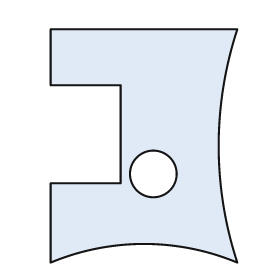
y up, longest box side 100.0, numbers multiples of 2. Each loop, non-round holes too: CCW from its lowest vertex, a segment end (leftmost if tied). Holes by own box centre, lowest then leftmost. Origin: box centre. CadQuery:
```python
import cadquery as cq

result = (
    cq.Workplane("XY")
    .moveTo(-40.0, -50.0)
    .threePointArc((0.0, -42.0), (40.0, -50.0))
    .threePointArc((32.0, 0.0), (40.0, 50.0))
    .lineTo(-40.0, 50.0)
    .lineTo(-40.0, 26.0)
    .lineTo(-10.0, 26.0)
    .lineTo(-10.0, -16.0)
    .lineTo(-40.0, -16.0)
    .close()
    .moveTo(4.0, -12.0)
    .circle(10.0)
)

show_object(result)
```